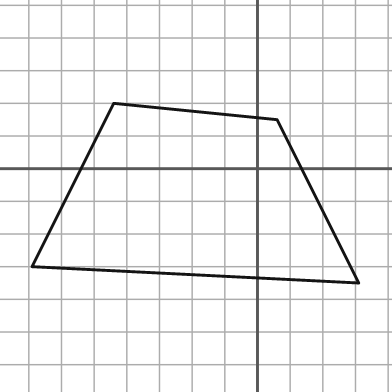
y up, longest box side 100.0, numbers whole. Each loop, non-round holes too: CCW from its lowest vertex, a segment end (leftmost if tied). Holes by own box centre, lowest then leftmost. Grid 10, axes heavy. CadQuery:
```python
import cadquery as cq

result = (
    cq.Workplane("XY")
    .moveTo(31.0, -35.0)
    .lineTo(6.0, 15.0)
    .lineTo(-44.0, 20.0)
    .lineTo(-69.0, -30.0)
    .close()
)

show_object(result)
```